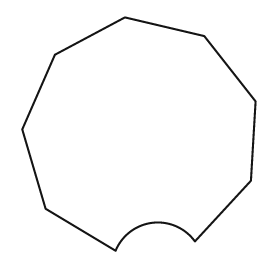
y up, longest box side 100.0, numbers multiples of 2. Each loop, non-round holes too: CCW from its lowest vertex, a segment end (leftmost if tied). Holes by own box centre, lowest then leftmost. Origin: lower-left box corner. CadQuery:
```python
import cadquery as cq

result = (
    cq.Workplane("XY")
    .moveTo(40.0, 0.0)
    .threePointArc((56.0, 12.0), (74.0, 4.0))
    .lineTo(98.0, 30.0)
    .lineTo(100.0, 64.0)
    .lineTo(78.0, 92.0)
    .lineTo(44.0, 100.0)
    .lineTo(14.0, 84.0)
    .lineTo(0.0, 52.0)
    .lineTo(10.0, 18.0)
    .close()
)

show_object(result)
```